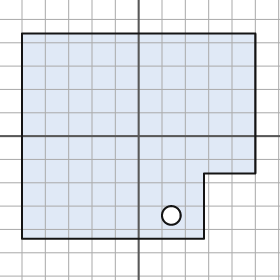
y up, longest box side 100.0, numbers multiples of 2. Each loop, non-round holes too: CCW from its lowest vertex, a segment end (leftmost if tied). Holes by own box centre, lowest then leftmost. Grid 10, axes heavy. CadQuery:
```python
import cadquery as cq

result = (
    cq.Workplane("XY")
    .moveTo(-50.0, -44.0)
    .lineTo(28.0, -44.0)
    .lineTo(28.0, -16.0)
    .lineTo(50.0, -16.0)
    .lineTo(50.0, 44.0)
    .lineTo(-50.0, 44.0)
    .close()
    .moveTo(14.0, -34.0)
    .circle(4.0)
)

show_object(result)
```